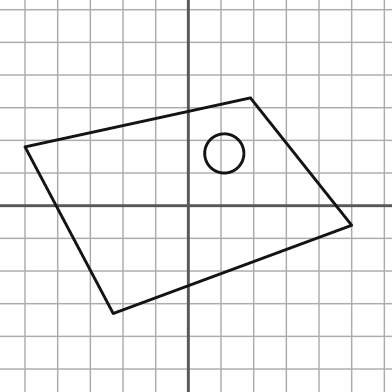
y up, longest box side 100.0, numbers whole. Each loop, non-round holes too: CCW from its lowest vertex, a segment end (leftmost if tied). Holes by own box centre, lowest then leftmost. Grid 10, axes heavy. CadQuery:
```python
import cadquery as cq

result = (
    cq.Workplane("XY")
    .moveTo(-23.0, -33.0)
    .lineTo(50.0, -6.0)
    .lineTo(19.0, 33.0)
    .lineTo(-50.0, 18.0)
    .close()
    .moveTo(11.0, 16.0)
    .circle(6.0)
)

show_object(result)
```